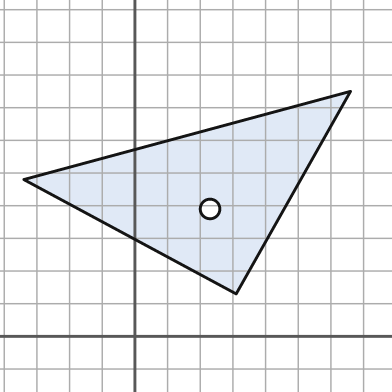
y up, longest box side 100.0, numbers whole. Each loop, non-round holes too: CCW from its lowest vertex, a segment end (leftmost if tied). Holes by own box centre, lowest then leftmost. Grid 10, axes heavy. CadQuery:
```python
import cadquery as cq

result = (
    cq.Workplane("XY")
    .moveTo(31.0, 13.0)
    .lineTo(66.0, 75.0)
    .lineTo(-34.0, 48.0)
    .close()
    .moveTo(23.0, 39.0)
    .circle(3.0)
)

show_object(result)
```